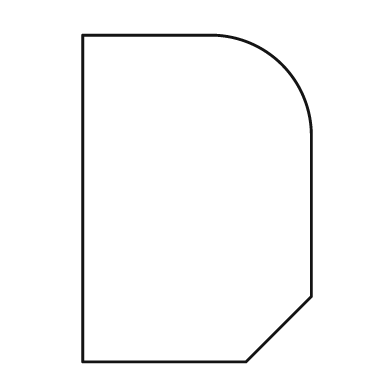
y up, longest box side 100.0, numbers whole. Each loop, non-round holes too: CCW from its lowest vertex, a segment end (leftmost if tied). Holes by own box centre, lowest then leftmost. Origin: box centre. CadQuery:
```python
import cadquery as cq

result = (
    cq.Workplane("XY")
    .moveTo(-35.0, -50.0)
    .lineTo(15.0, -50.0)
    .lineTo(35.0, -30.0)
    .lineTo(35.0, 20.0)
    .threePointArc((26.0, 41.0), (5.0, 50.0))
    .lineTo(-35.0, 50.0)
    .close()
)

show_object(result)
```